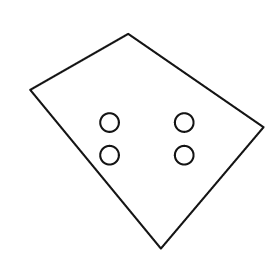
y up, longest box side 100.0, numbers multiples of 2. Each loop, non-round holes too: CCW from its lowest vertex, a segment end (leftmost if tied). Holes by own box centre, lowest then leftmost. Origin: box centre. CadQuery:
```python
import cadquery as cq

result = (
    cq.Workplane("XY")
    .moveTo(6.0, -46.0)
    .lineTo(50.0, 6.0)
    .lineTo(-8.0, 46.0)
    .lineTo(-50.0, 22.0)
    .close()
    .moveTo(-16.0, -6.0)
    .circle(4.0)
    .moveTo(16.0, -6.0)
    .circle(4.0)
    .moveTo(-16.0, 8.0)
    .circle(4.0)
    .moveTo(16.0, 8.0)
    .circle(4.0)
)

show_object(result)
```